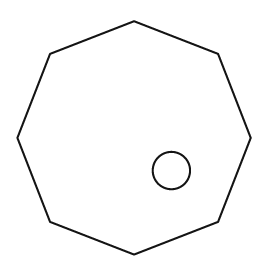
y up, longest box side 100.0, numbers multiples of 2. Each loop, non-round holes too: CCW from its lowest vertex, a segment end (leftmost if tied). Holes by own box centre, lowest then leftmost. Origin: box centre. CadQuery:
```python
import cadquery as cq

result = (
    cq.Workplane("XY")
    .moveTo(0.0, -50.0)
    .lineTo(36.0, -36.0)
    .lineTo(50.0, 0.0)
    .lineTo(36.0, 36.0)
    .lineTo(0.0, 50.0)
    .lineTo(-36.0, 36.0)
    .lineTo(-50.0, 0.0)
    .lineTo(-36.0, -36.0)
    .close()
    .moveTo(16.0, -14.0)
    .circle(8.0)
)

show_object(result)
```